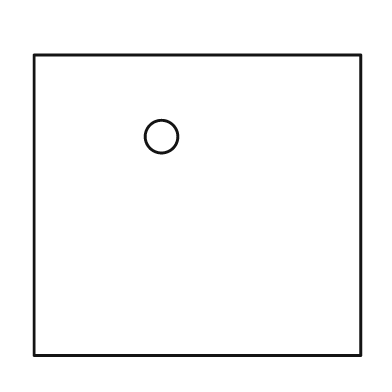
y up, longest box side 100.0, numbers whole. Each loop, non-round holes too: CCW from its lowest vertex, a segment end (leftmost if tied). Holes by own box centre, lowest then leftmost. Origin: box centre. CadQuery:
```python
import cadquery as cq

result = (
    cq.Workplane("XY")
    .moveTo(-50.0, -46.0)
    .lineTo(50.0, -46.0)
    .lineTo(50.0, 46.0)
    .lineTo(-50.0, 46.0)
    .close()
    .moveTo(-11.0, 21.0)
    .circle(5.0)
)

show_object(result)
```